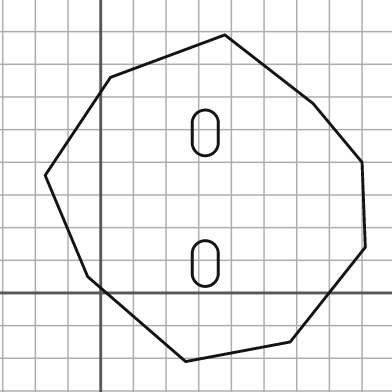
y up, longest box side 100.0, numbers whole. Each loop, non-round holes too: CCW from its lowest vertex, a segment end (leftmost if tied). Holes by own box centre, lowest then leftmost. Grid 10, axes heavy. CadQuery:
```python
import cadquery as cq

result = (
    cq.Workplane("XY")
    .moveTo(26.0, -21.0)
    .lineTo(58.0, -15.0)
    .lineTo(81.0, 14.0)
    .lineTo(80.0, 40.0)
    .lineTo(65.0, 58.0)
    .lineTo(38.0, 79.0)
    .lineTo(3.0, 66.0)
    .lineTo(-17.0, 36.0)
    .lineTo(-4.0, 5.0)
    .close()
    .moveTo(28.0, 6.0)
    .threePointArc((32.0, 2.0), (36.0, 6.0))
    .lineTo(36.0, 12.0)
    .threePointArc((32.0, 16.0), (28.0, 12.0))
    .close()
    .moveTo(28.0, 46.0)
    .threePointArc((32.0, 42.0), (36.0, 46.0))
    .lineTo(36.0, 52.0)
    .threePointArc((32.0, 56.0), (28.0, 52.0))
    .close()
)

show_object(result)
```